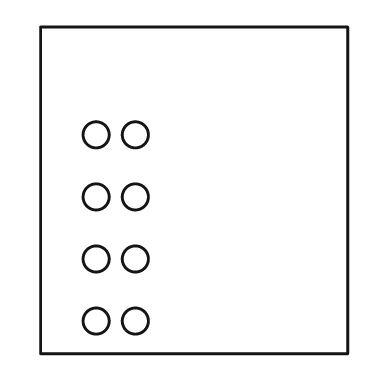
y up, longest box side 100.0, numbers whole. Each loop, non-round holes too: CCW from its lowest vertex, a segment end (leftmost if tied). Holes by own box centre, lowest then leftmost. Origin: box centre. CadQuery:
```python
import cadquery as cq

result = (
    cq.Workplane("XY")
    .moveTo(-47.0, -50.0)
    .lineTo(47.0, -50.0)
    .lineTo(47.0, 50.0)
    .lineTo(-47.0, 50.0)
    .close()
    .moveTo(-30.0, -40.0)
    .circle(4.0)
    .moveTo(-18.0, -40.0)
    .circle(4.0)
    .moveTo(-30.0, -21.0)
    .circle(4.0)
    .moveTo(-18.0, -21.0)
    .circle(4.0)
    .moveTo(-30.0, -2.0)
    .circle(4.0)
    .moveTo(-18.0, -2.0)
    .circle(4.0)
    .moveTo(-30.0, 17.0)
    .circle(4.0)
    .moveTo(-18.0, 17.0)
    .circle(4.0)
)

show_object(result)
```